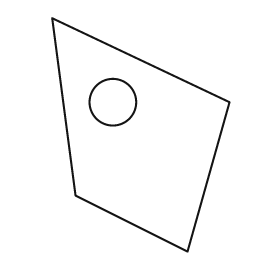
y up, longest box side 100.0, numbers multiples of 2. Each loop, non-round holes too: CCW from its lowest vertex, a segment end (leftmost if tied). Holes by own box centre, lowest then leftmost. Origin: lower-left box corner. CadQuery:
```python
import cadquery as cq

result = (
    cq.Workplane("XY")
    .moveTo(58.0, 0.0)
    .lineTo(76.0, 64.0)
    .lineTo(0.0, 100.0)
    .lineTo(10.0, 24.0)
    .close()
    .moveTo(26.0, 64.0)
    .circle(10.0)
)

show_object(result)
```